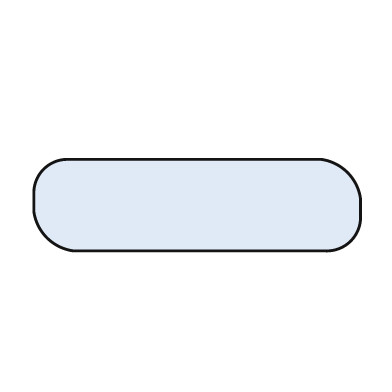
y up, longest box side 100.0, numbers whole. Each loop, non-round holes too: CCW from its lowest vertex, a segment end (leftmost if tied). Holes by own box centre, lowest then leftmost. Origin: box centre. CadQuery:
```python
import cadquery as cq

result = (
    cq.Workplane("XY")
    .moveTo(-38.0, -14.0)
    .lineTo(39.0, -14.0)
    .threePointArc((47.0, -11.0), (50.0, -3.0))
    .lineTo(50.0, 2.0)
    .threePointArc((46.0, 10.0), (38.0, 14.0))
    .lineTo(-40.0, 14.0)
    .threePointArc((-47.0, 11.0), (-50.0, 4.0))
    .lineTo(-50.0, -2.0)
    .threePointArc((-46.0, -10.0), (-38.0, -14.0))
    .close()
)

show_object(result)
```